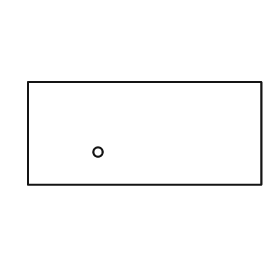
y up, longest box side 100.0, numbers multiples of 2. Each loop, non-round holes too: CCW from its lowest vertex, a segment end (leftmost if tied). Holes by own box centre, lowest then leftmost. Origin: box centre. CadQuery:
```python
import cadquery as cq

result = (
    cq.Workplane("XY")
    .moveTo(-50.0, -22.0)
    .lineTo(50.0, -22.0)
    .lineTo(50.0, 22.0)
    .lineTo(-50.0, 22.0)
    .close()
    .moveTo(-20.0, -8.0)
    .circle(2.0)
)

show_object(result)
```